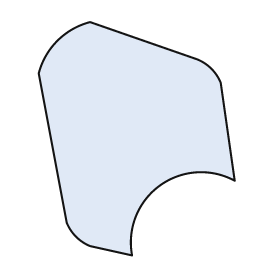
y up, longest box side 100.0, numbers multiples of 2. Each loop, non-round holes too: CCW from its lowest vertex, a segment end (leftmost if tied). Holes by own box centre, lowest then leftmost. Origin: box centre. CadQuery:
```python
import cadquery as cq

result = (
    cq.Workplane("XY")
    .moveTo(-2.0, -50.0)
    .threePointArc((10.0, -20.0), (42.0, -18.0))
    .lineTo(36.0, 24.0)
    .threePointArc((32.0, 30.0), (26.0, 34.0))
    .lineTo(-20.0, 50.0)
    .threePointArc((-34.0, 42.0), (-42.0, 28.0))
    .lineTo(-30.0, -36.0)
    .threePointArc((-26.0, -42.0), (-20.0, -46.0))
    .close()
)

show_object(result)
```